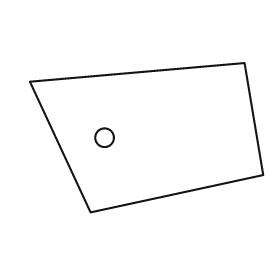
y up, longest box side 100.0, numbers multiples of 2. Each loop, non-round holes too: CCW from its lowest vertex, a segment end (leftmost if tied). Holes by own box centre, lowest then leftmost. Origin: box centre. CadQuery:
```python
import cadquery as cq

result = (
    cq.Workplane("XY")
    .moveTo(-24.0, -32.0)
    .lineTo(50.0, -16.0)
    .lineTo(42.0, 32.0)
    .lineTo(-50.0, 24.0)
    .close()
    .moveTo(-18.0, 0.0)
    .circle(4.0)
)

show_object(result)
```